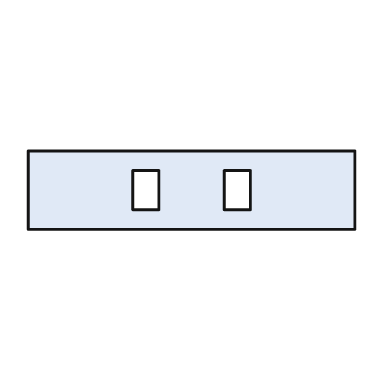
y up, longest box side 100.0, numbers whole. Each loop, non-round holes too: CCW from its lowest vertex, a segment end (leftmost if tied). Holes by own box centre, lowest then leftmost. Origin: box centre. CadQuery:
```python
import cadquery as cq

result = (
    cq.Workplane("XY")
    .moveTo(-50.0, -12.0)
    .lineTo(50.0, -12.0)
    .lineTo(50.0, 12.0)
    .lineTo(-50.0, 12.0)
    .close()
    .moveTo(-18.0, -6.0)
    .lineTo(-10.0, -6.0)
    .lineTo(-10.0, 6.0)
    .lineTo(-18.0, 6.0)
    .close()
    .moveTo(10.0, -6.0)
    .lineTo(18.0, -6.0)
    .lineTo(18.0, 6.0)
    .lineTo(10.0, 6.0)
    .close()
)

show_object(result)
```